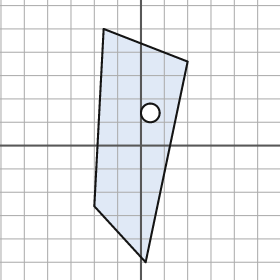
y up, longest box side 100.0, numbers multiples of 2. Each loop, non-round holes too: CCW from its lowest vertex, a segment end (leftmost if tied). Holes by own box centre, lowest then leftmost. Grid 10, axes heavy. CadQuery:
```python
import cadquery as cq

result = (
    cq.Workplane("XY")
    .moveTo(2.0, -50.0)
    .lineTo(20.0, 36.0)
    .lineTo(-16.0, 50.0)
    .lineTo(-20.0, -26.0)
    .close()
    .moveTo(4.0, 14.0)
    .circle(4.0)
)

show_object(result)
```